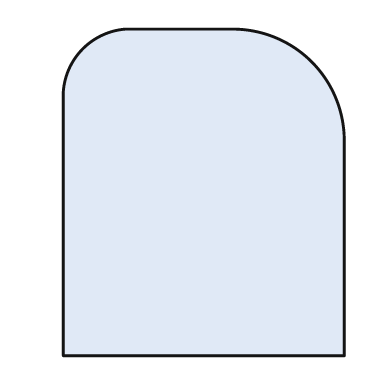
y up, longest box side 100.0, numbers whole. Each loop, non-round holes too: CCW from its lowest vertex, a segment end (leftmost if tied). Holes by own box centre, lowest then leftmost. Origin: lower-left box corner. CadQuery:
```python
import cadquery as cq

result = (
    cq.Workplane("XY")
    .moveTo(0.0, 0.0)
    .lineTo(86.0, 0.0)
    .lineTo(86.0, 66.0)
    .threePointArc((76.0, 90.0), (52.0, 100.0))
    .lineTo(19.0, 100.0)
    .threePointArc((6.0, 94.0), (0.0, 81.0))
    .close()
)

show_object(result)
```